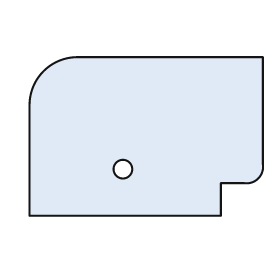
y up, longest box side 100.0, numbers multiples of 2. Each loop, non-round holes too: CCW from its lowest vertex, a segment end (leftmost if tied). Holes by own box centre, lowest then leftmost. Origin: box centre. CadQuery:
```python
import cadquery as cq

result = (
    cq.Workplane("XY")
    .moveTo(-50.0, -34.0)
    .lineTo(32.0, -34.0)
    .lineTo(32.0, -20.0)
    .lineTo(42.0, -20.0)
    .threePointArc((48.0, -18.0), (50.0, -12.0))
    .lineTo(50.0, 34.0)
    .lineTo(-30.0, 34.0)
    .threePointArc((-44.0, 28.0), (-50.0, 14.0))
    .close()
    .moveTo(-10.0, -14.0)
    .circle(4.0)
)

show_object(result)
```